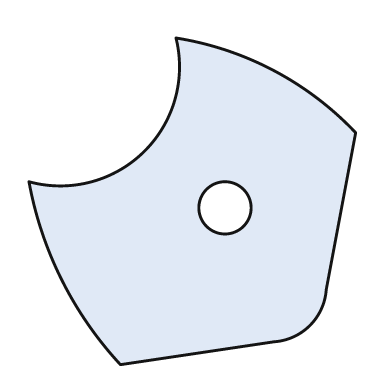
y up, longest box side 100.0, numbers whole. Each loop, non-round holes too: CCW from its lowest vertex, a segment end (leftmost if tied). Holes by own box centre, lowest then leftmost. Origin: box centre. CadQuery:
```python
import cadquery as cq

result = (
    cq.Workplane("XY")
    .moveTo(-22.0, -50.0)
    .lineTo(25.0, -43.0)
    .threePointArc((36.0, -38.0), (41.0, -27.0))
    .lineTo(50.0, 21.0)
    .threePointArc((25.0, 40.0), (-5.0, 50.0))
    .threePointArc((-15.0, 15.0), (-50.0, 6.0))
    .threePointArc((-40.0, -24.0), (-22.0, -50.0))
    .close()
    .moveTo(10.0, -2.0)
    .circle(8.0)
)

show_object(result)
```